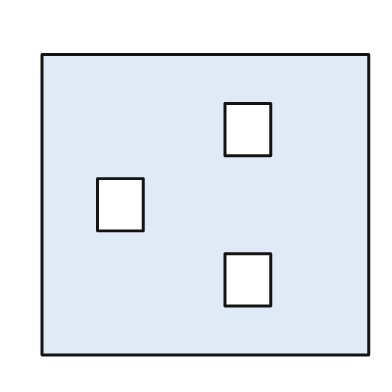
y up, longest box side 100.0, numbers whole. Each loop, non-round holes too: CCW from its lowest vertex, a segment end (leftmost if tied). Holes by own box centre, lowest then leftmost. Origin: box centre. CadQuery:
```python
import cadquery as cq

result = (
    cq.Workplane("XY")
    .moveTo(-50.0, -46.0)
    .lineTo(50.0, -46.0)
    .lineTo(50.0, 46.0)
    .lineTo(-50.0, 46.0)
    .close()
    .moveTo(6.0, -31.0)
    .lineTo(20.0, -31.0)
    .lineTo(20.0, -15.0)
    .lineTo(6.0, -15.0)
    .close()
    .moveTo(-33.0, -8.0)
    .lineTo(-19.0, -8.0)
    .lineTo(-19.0, 8.0)
    .lineTo(-33.0, 8.0)
    .close()
    .moveTo(6.0, 15.0)
    .lineTo(20.0, 15.0)
    .lineTo(20.0, 31.0)
    .lineTo(6.0, 31.0)
    .close()
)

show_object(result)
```